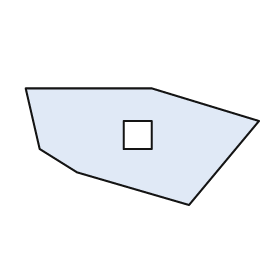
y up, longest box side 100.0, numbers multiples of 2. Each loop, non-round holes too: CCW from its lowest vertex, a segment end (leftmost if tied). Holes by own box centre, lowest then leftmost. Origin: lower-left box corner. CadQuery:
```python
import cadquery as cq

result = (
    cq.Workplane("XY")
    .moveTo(70.0, 0.0)
    .lineTo(100.0, 36.0)
    .lineTo(54.0, 50.0)
    .lineTo(0.0, 50.0)
    .lineTo(6.0, 24.0)
    .lineTo(22.0, 14.0)
    .close()
    .moveTo(42.0, 24.0)
    .lineTo(54.0, 24.0)
    .lineTo(54.0, 36.0)
    .lineTo(42.0, 36.0)
    .close()
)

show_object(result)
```